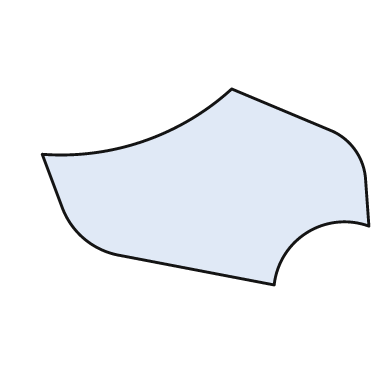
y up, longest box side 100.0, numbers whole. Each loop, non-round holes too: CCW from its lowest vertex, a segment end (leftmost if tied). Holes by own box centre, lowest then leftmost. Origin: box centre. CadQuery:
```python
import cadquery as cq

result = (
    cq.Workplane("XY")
    .moveTo(21.0, -30.0)
    .threePointArc((31.0, -14.0), (50.0, -12.0))
    .lineTo(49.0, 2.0)
    .threePointArc((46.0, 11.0), (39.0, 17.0))
    .lineTo(8.0, 30.0)
    .threePointArc((-19.0, 14.0), (-50.0, 10.0))
    .lineTo(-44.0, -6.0)
    .threePointArc((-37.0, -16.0), (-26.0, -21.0))
    .close()
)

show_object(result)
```